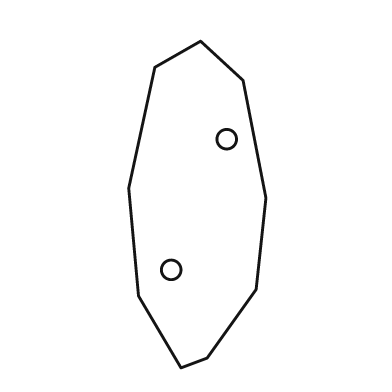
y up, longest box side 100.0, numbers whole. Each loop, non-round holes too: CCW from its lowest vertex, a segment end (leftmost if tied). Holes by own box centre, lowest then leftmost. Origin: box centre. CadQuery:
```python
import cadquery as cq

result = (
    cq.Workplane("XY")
    .moveTo(-5.0, -50.0)
    .lineTo(3.0, -47.0)
    .lineTo(18.0, -26.0)
    .lineTo(21.0, 2.0)
    .lineTo(14.0, 38.0)
    .lineTo(1.0, 50.0)
    .lineTo(-13.0, 42.0)
    .lineTo(-21.0, 5.0)
    .lineTo(-18.0, -28.0)
    .close()
    .moveTo(-8.0, -20.0)
    .circle(3.0)
    .moveTo(9.0, 20.0)
    .circle(3.0)
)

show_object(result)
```